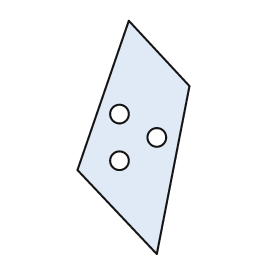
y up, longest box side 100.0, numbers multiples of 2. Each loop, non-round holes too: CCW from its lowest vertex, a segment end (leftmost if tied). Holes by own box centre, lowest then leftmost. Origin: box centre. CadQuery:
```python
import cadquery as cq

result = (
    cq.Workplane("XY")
    .moveTo(10.0, -50.0)
    .lineTo(24.0, 22.0)
    .lineTo(-2.0, 50.0)
    .lineTo(-24.0, -14.0)
    .close()
    .moveTo(-6.0, -10.0)
    .circle(4.0)
    .moveTo(10.0, 0.0)
    .circle(4.0)
    .moveTo(-6.0, 10.0)
    .circle(4.0)
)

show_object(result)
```